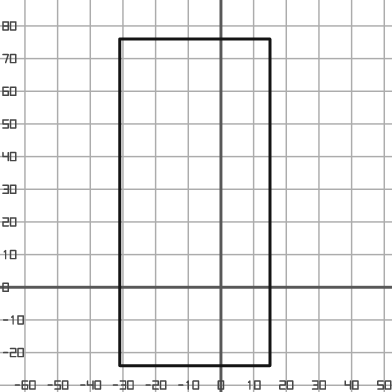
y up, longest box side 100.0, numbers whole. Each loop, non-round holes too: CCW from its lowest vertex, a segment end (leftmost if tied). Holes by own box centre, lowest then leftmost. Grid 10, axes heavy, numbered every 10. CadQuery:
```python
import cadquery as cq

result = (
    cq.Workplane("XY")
    .moveTo(-31.0, -24.0)
    .lineTo(15.0, -24.0)
    .lineTo(15.0, 76.0)
    .lineTo(-31.0, 76.0)
    .close()
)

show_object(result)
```